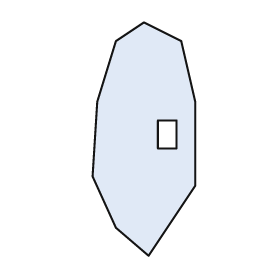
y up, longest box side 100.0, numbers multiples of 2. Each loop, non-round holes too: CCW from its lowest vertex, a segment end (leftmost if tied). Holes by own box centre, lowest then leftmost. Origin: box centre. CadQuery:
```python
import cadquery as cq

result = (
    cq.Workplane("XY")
    .moveTo(2.0, -50.0)
    .lineTo(22.0, -20.0)
    .lineTo(22.0, 16.0)
    .lineTo(16.0, 42.0)
    .lineTo(0.0, 50.0)
    .lineTo(-12.0, 42.0)
    .lineTo(-20.0, 16.0)
    .lineTo(-22.0, -16.0)
    .lineTo(-12.0, -38.0)
    .close()
    .moveTo(6.0, -4.0)
    .lineTo(14.0, -4.0)
    .lineTo(14.0, 8.0)
    .lineTo(6.0, 8.0)
    .close()
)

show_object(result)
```